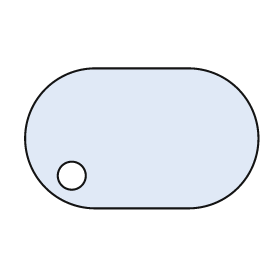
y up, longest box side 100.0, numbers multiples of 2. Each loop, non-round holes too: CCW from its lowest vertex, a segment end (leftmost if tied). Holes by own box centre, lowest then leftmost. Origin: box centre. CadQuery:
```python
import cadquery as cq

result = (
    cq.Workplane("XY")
    .moveTo(-20.0, -30.0)
    .lineTo(20.0, -30.0)
    .threePointArc((50.0, 0.0), (20.0, 30.0))
    .lineTo(-20.0, 30.0)
    .threePointArc((-50.0, 0.0), (-20.0, -30.0))
    .close()
    .moveTo(-30.0, -16.0)
    .circle(6.0)
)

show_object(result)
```